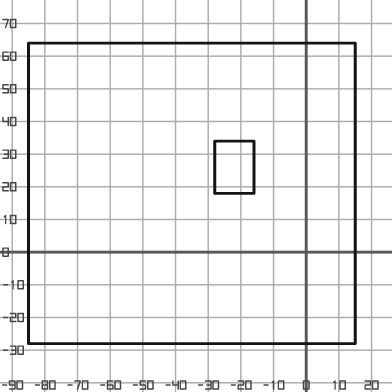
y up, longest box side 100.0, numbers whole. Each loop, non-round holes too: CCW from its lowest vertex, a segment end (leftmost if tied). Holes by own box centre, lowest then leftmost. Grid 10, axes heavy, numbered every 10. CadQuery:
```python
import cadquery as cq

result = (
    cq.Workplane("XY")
    .moveTo(-85.0, -28.0)
    .lineTo(15.0, -28.0)
    .lineTo(15.0, 64.0)
    .lineTo(-85.0, 64.0)
    .close()
    .moveTo(-28.0, 18.0)
    .lineTo(-16.0, 18.0)
    .lineTo(-16.0, 34.0)
    .lineTo(-28.0, 34.0)
    .close()
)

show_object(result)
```